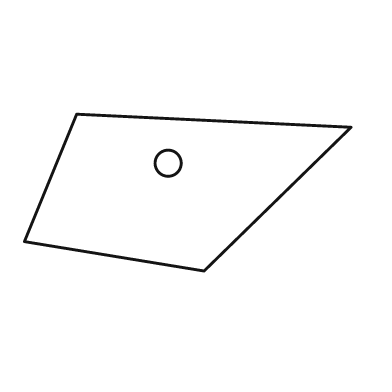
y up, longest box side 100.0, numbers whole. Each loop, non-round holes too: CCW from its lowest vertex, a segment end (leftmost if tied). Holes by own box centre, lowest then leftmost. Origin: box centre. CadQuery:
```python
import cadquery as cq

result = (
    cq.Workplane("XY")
    .moveTo(5.0, -24.0)
    .lineTo(50.0, 20.0)
    .lineTo(-34.0, 24.0)
    .lineTo(-50.0, -15.0)
    .close()
    .moveTo(-6.0, 9.0)
    .circle(4.0)
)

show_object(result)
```